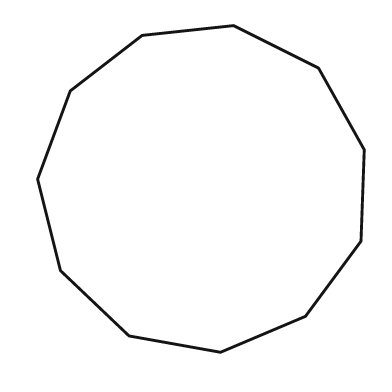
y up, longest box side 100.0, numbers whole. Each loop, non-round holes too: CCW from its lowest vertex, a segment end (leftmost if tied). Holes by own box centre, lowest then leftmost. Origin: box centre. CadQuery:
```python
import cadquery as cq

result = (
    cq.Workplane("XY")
    .moveTo(6.0, -50.0)
    .lineTo(32.0, -39.0)
    .lineTo(49.0, -16.0)
    .lineTo(50.0, 12.0)
    .lineTo(36.0, 37.0)
    .lineTo(10.0, 50.0)
    .lineTo(-18.0, 47.0)
    .lineTo(-40.0, 30.0)
    .lineTo(-50.0, 3.0)
    .lineTo(-43.0, -25.0)
    .lineTo(-22.0, -45.0)
    .close()
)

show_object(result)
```